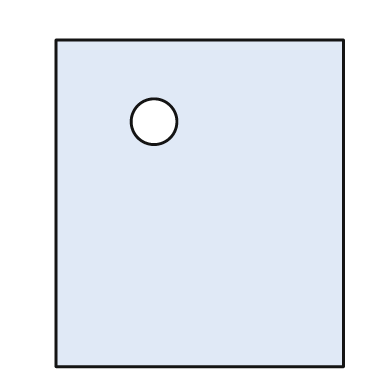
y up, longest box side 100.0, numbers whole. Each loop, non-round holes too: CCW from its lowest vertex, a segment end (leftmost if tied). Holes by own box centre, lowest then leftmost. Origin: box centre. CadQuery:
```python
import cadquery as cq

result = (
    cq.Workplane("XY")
    .moveTo(-44.0, -50.0)
    .lineTo(44.0, -50.0)
    .lineTo(44.0, 50.0)
    .lineTo(-44.0, 50.0)
    .close()
    .moveTo(-14.0, 25.0)
    .circle(7.0)
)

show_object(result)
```